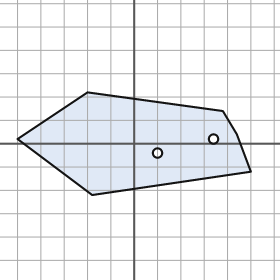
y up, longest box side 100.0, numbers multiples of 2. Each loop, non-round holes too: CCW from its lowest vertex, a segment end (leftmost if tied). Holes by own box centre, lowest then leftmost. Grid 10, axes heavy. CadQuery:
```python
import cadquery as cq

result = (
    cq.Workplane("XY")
    .moveTo(-18.0, -22.0)
    .lineTo(50.0, -12.0)
    .lineTo(44.0, 4.0)
    .lineTo(38.0, 14.0)
    .lineTo(-20.0, 22.0)
    .lineTo(-50.0, 2.0)
    .close()
    .moveTo(10.0, -4.0)
    .circle(2.0)
    .moveTo(34.0, 2.0)
    .circle(2.0)
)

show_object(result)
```